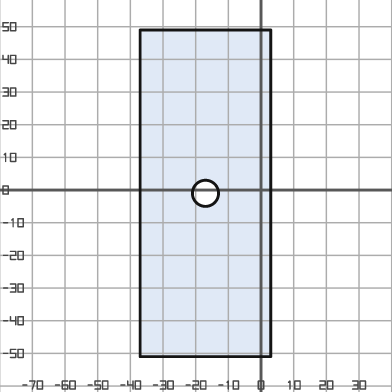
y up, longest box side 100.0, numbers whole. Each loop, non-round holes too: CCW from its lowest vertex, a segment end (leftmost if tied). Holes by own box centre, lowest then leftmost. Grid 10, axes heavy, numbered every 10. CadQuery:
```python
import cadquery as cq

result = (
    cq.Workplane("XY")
    .moveTo(-37.0, -51.0)
    .lineTo(3.0, -51.0)
    .lineTo(3.0, 49.0)
    .lineTo(-37.0, 49.0)
    .close()
    .moveTo(-17.0, -1.0)
    .circle(4.0)
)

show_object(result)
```